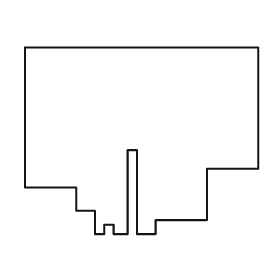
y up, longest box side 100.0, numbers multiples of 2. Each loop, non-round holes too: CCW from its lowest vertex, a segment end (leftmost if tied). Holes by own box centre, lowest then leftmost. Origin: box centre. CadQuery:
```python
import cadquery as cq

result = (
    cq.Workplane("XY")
    .moveTo(-20.0, -40.0)
    .lineTo(-16.0, -40.0)
    .lineTo(-16.0, -36.0)
    .lineTo(-12.0, -36.0)
    .lineTo(-12.0, -40.0)
    .lineTo(-6.0, -40.0)
    .lineTo(-6.0, -4.0)
    .lineTo(-2.0, -4.0)
    .lineTo(-2.0, -40.0)
    .lineTo(6.0, -40.0)
    .lineTo(6.0, -34.0)
    .lineTo(28.0, -34.0)
    .lineTo(28.0, -12.0)
    .lineTo(50.0, -12.0)
    .lineTo(50.0, 40.0)
    .lineTo(-50.0, 40.0)
    .lineTo(-50.0, -20.0)
    .lineTo(-28.0, -20.0)
    .lineTo(-28.0, -30.0)
    .lineTo(-20.0, -30.0)
    .close()
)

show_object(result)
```